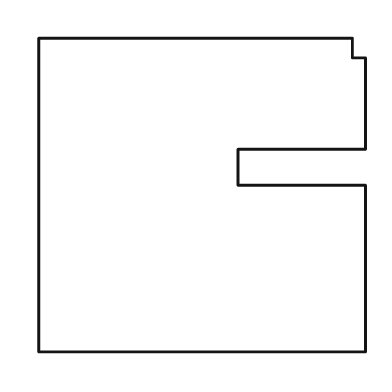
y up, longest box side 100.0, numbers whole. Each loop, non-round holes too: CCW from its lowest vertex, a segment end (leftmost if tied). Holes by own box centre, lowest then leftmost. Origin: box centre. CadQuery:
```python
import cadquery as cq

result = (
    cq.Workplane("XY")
    .moveTo(-50.0, -48.0)
    .lineTo(50.0, -48.0)
    .lineTo(50.0, 3.0)
    .lineTo(11.0, 3.0)
    .lineTo(11.0, 14.0)
    .lineTo(50.0, 14.0)
    .lineTo(50.0, 42.0)
    .lineTo(46.0, 42.0)
    .lineTo(46.0, 48.0)
    .lineTo(-50.0, 48.0)
    .close()
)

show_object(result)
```